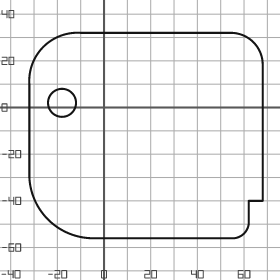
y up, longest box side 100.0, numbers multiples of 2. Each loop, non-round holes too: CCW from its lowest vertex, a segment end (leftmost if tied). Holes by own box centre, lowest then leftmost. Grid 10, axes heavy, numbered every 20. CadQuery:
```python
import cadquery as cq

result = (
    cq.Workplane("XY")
    .moveTo(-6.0, -56.0)
    .lineTo(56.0, -56.0)
    .threePointArc((60.0, -54.0), (62.0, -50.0))
    .lineTo(62.0, -40.0)
    .lineTo(68.0, -40.0)
    .lineTo(68.0, 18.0)
    .threePointArc((64.0, 28.0), (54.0, 32.0))
    .lineTo(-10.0, 32.0)
    .threePointArc((-26.0, 26.0), (-32.0, 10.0))
    .lineTo(-32.0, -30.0)
    .threePointArc((-24.0, -48.0), (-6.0, -56.0))
    .close()
    .moveTo(-18.0, 2.0)
    .circle(6.0)
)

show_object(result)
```